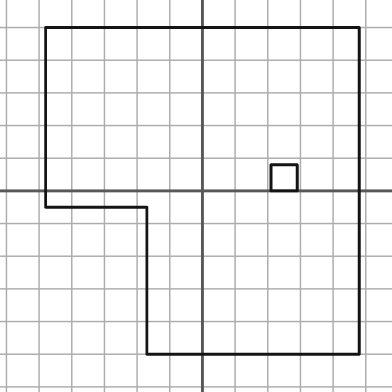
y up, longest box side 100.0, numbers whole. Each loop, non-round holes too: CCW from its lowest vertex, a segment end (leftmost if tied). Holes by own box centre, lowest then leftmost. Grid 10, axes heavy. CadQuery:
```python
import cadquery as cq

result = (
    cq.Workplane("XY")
    .moveTo(-17.0, -50.0)
    .lineTo(48.0, -50.0)
    .lineTo(48.0, 50.0)
    .lineTo(-48.0, 50.0)
    .lineTo(-48.0, -5.0)
    .lineTo(-17.0, -5.0)
    .close()
    .moveTo(21.0, 0.0)
    .lineTo(29.0, 0.0)
    .lineTo(29.0, 8.0)
    .lineTo(21.0, 8.0)
    .close()
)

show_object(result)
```